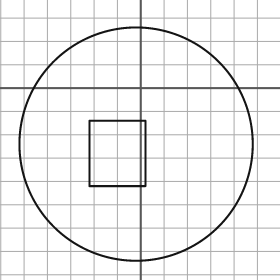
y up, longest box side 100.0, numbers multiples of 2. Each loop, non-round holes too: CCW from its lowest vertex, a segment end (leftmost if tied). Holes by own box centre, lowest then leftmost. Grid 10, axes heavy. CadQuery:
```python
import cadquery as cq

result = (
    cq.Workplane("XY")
    .moveTo(-2.0, -24.0)
    .circle(50.0)
    .moveTo(-22.0, -42.0)
    .lineTo(2.0, -42.0)
    .lineTo(2.0, -14.0)
    .lineTo(-22.0, -14.0)
    .close()
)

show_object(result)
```